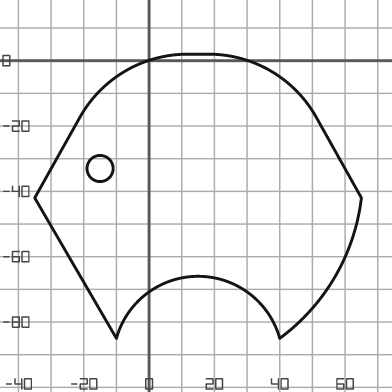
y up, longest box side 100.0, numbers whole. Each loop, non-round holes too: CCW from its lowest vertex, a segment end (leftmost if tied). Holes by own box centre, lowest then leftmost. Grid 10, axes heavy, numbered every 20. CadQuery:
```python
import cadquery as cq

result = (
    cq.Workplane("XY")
    .moveTo(-10.0, -85.0)
    .threePointArc((15.0, -66.0), (40.0, -85.0))
    .threePointArc((57.0, -66.0), (65.0, -42.0))
    .lineTo(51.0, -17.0)
    .threePointArc((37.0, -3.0), (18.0, 2.0))
    .lineTo(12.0, 2.0)
    .threePointArc((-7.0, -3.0), (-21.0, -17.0))
    .lineTo(-35.0, -42.0)
    .close()
    .moveTo(-15.0, -33.0)
    .circle(4.0)
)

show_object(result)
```